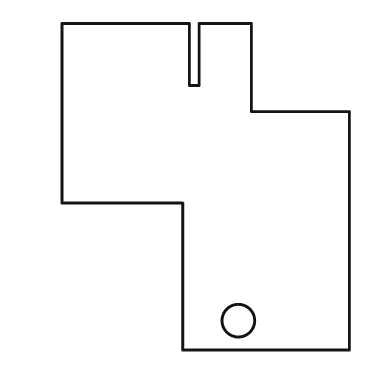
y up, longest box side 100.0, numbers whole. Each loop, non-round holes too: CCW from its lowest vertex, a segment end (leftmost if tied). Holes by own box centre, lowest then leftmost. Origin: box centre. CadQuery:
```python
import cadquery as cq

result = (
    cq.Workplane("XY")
    .moveTo(-7.0, -50.0)
    .lineTo(44.0, -50.0)
    .lineTo(44.0, 23.0)
    .lineTo(14.0, 23.0)
    .lineTo(14.0, 50.0)
    .lineTo(-2.0, 50.0)
    .lineTo(-2.0, 31.0)
    .lineTo(-5.0, 31.0)
    .lineTo(-5.0, 50.0)
    .lineTo(-44.0, 50.0)
    .lineTo(-44.0, -5.0)
    .lineTo(-7.0, -5.0)
    .close()
    .moveTo(10.0, -41.0)
    .circle(5.0)
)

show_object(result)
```